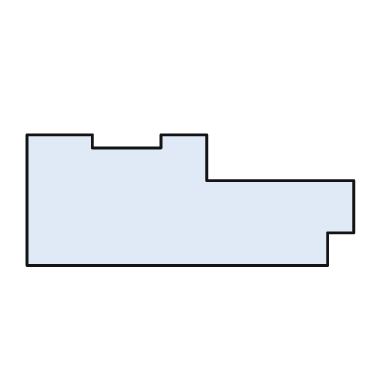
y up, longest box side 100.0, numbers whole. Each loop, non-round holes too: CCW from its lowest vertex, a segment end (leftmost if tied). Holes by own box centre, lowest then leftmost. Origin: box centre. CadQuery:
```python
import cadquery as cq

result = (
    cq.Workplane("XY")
    .moveTo(-50.0, -20.0)
    .lineTo(42.0, -20.0)
    .lineTo(42.0, -10.0)
    .lineTo(50.0, -10.0)
    .lineTo(50.0, 6.0)
    .lineTo(5.0, 6.0)
    .lineTo(5.0, 20.0)
    .lineTo(-9.0, 20.0)
    .lineTo(-9.0, 16.0)
    .lineTo(-30.0, 16.0)
    .lineTo(-30.0, 20.0)
    .lineTo(-50.0, 20.0)
    .close()
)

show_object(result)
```